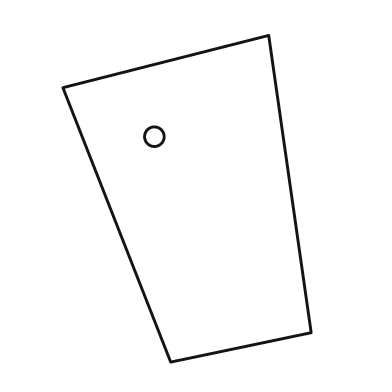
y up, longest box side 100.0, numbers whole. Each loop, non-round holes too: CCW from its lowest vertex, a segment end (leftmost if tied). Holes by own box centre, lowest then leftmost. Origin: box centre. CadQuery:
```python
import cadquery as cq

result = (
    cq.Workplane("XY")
    .moveTo(-5.0, -50.0)
    .lineTo(38.0, -41.0)
    .lineTo(25.0, 50.0)
    .lineTo(-38.0, 34.0)
    .close()
    .moveTo(-10.0, 19.0)
    .circle(3.0)
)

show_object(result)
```